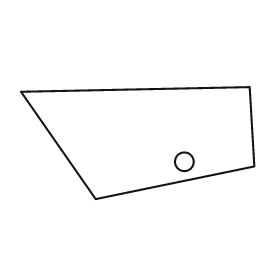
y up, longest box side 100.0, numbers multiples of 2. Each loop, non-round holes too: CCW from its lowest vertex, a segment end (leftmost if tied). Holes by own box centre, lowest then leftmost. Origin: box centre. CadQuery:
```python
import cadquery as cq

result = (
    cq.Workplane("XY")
    .moveTo(-18.0, -24.0)
    .lineTo(50.0, -10.0)
    .lineTo(48.0, 24.0)
    .lineTo(-50.0, 22.0)
    .close()
    .moveTo(20.0, -8.0)
    .circle(4.0)
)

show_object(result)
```